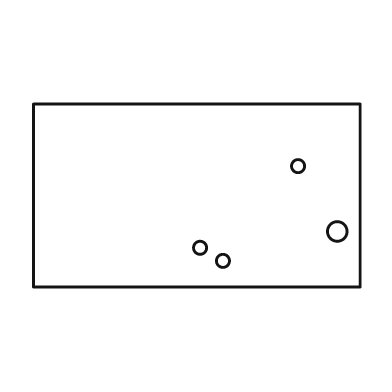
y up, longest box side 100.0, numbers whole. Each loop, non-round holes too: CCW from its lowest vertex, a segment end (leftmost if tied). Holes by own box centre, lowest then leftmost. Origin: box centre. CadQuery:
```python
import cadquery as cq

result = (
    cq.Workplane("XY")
    .moveTo(-50.0, -28.0)
    .lineTo(50.0, -28.0)
    .lineTo(50.0, 28.0)
    .lineTo(-50.0, 28.0)
    .close()
    .moveTo(8.0, -20.0)
    .circle(2.0)
    .moveTo(1.0, -16.0)
    .circle(2.0)
    .moveTo(43.0, -11.0)
    .circle(3.0)
    .moveTo(31.0, 9.0)
    .circle(2.0)
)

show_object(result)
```